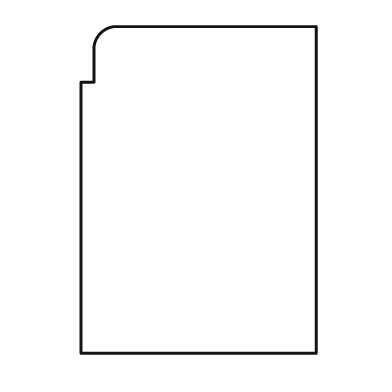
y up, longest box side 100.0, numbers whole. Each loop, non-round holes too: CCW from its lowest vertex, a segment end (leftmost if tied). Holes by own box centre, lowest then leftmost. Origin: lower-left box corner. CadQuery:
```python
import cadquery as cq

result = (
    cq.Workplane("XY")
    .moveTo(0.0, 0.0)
    .lineTo(72.0, 0.0)
    .lineTo(72.0, 100.0)
    .lineTo(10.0, 100.0)
    .threePointArc((6.0, 98.0), (4.0, 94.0))
    .lineTo(4.0, 83.0)
    .lineTo(0.0, 83.0)
    .close()
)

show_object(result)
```